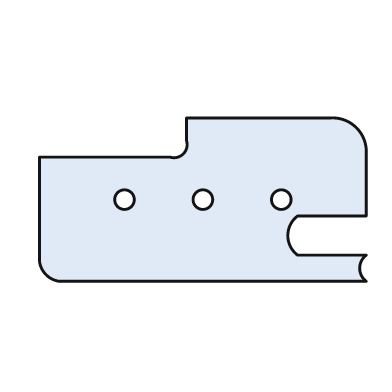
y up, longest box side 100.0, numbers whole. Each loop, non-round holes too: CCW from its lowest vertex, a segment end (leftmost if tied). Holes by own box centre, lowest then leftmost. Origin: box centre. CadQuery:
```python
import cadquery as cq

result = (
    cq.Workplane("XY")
    .moveTo(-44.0, -25.0)
    .lineTo(50.0, -25.0)
    .threePointArc((48.0, -21.0), (50.0, -17.0))
    .lineTo(29.0, -17.0)
    .threePointArc((26.0, -11.0), (29.0, -5.0))
    .lineTo(50.0, -5.0)
    .lineTo(50.0, 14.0)
    .threePointArc((47.0, 22.0), (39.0, 25.0))
    .lineTo(-5.0, 25.0)
    .lineTo(-5.0, 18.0)
    .threePointArc((-6.0, 14.0), (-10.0, 13.0))
    .lineTo(-50.0, 13.0)
    .lineTo(-50.0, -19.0)
    .threePointArc((-48.0, -23.0), (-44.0, -25.0))
    .close()
    .moveTo(-24.0, 0.0)
    .circle(3.0)
    .moveTo(0.0, 0.0)
    .circle(3.0)
    .moveTo(24.0, 0.0)
    .circle(3.0)
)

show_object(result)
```